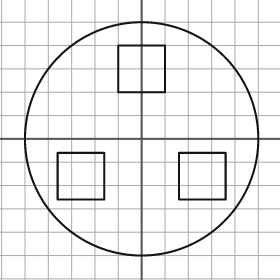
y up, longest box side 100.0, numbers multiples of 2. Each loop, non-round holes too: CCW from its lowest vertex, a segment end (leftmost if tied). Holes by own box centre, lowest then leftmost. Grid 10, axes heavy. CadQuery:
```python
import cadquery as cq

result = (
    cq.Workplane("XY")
    .moveTo(0.0, 0.0)
    .circle(50.0)
    .moveTo(-36.0, -26.0)
    .lineTo(-16.0, -26.0)
    .lineTo(-16.0, -6.0)
    .lineTo(-36.0, -6.0)
    .close()
    .moveTo(16.0, -26.0)
    .lineTo(36.0, -26.0)
    .lineTo(36.0, -6.0)
    .lineTo(16.0, -6.0)
    .close()
    .moveTo(-10.0, 20.0)
    .lineTo(10.0, 20.0)
    .lineTo(10.0, 40.0)
    .lineTo(-10.0, 40.0)
    .close()
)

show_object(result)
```